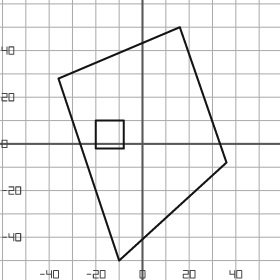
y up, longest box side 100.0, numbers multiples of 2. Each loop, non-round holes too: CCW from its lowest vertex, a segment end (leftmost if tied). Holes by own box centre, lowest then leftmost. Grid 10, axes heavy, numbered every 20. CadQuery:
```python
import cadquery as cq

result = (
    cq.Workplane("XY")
    .moveTo(-10.0, -50.0)
    .lineTo(36.0, -8.0)
    .lineTo(16.0, 50.0)
    .lineTo(-36.0, 28.0)
    .close()
    .moveTo(-20.0, -2.0)
    .lineTo(-8.0, -2.0)
    .lineTo(-8.0, 10.0)
    .lineTo(-20.0, 10.0)
    .close()
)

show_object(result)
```